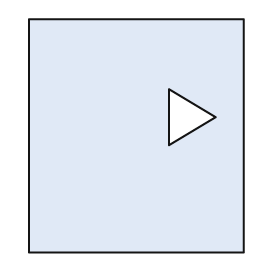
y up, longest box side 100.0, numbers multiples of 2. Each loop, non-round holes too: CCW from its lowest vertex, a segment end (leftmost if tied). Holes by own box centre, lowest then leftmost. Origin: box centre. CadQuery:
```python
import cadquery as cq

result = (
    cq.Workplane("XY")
    .moveTo(-46.0, -50.0)
    .lineTo(46.0, -50.0)
    .lineTo(46.0, 50.0)
    .lineTo(-46.0, 50.0)
    .close()
    .moveTo(14.0, -4.0)
    .lineTo(34.0, 8.0)
    .lineTo(14.0, 20.0)
    .close()
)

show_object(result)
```